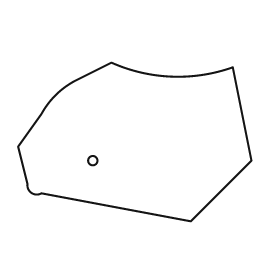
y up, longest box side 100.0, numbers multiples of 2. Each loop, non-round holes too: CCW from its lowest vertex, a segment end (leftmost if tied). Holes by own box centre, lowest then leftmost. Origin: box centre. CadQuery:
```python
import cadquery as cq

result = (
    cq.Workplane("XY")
    .moveTo(24.0, -34.0)
    .lineTo(50.0, -8.0)
    .lineTo(42.0, 32.0)
    .threePointArc((16.0, 28.0), (-10.0, 34.0))
    .lineTo(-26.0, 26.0)
    .threePointArc((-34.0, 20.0), (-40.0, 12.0))
    .lineTo(-50.0, -2.0)
    .lineTo(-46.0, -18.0)
    .threePointArc((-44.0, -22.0), (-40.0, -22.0))
    .close()
    .moveTo(-18.0, -8.0)
    .circle(2.0)
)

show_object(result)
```